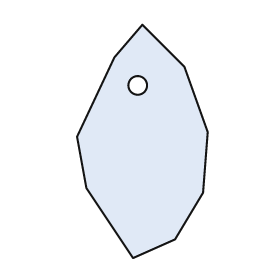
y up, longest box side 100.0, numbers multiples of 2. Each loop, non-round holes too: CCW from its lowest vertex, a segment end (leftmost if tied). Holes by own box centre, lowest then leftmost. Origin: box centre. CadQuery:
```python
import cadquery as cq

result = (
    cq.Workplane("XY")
    .moveTo(-4.0, -50.0)
    .lineTo(14.0, -42.0)
    .lineTo(26.0, -22.0)
    .lineTo(28.0, 4.0)
    .lineTo(18.0, 32.0)
    .lineTo(0.0, 50.0)
    .lineTo(-12.0, 36.0)
    .lineTo(-28.0, 2.0)
    .lineTo(-24.0, -20.0)
    .close()
    .moveTo(-2.0, 24.0)
    .circle(4.0)
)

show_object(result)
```